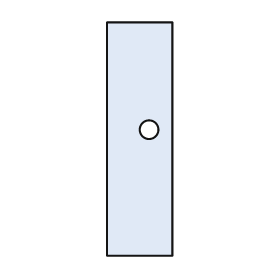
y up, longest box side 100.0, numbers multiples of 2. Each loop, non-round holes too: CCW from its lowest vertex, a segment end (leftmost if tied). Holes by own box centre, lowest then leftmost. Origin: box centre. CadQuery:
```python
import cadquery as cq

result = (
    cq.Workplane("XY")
    .moveTo(-14.0, -50.0)
    .lineTo(14.0, -50.0)
    .lineTo(14.0, 50.0)
    .lineTo(-14.0, 50.0)
    .close()
    .moveTo(4.0, 4.0)
    .circle(4.0)
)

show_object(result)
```